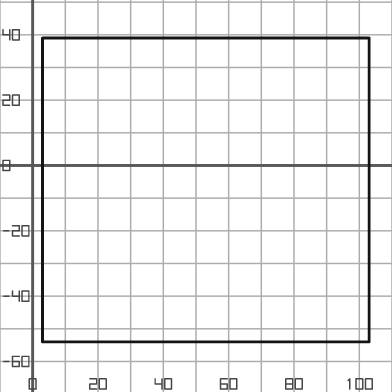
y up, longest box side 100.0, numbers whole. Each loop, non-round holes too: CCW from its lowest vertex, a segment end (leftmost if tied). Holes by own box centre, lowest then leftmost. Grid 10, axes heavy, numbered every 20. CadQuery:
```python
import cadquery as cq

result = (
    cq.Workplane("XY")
    .moveTo(3.0, -54.0)
    .lineTo(103.0, -54.0)
    .lineTo(103.0, 39.0)
    .lineTo(3.0, 39.0)
    .close()
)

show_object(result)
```